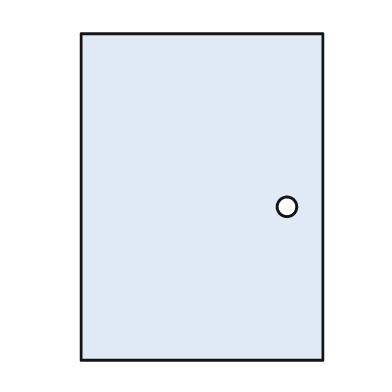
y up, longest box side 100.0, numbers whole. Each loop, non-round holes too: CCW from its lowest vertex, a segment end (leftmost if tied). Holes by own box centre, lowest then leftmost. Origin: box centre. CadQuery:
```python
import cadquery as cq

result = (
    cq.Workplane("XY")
    .moveTo(-37.0, -50.0)
    .lineTo(37.0, -50.0)
    .lineTo(37.0, 50.0)
    .lineTo(-37.0, 50.0)
    .close()
    .moveTo(26.0, -3.0)
    .circle(3.0)
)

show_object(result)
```